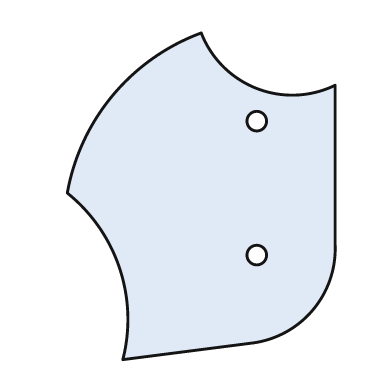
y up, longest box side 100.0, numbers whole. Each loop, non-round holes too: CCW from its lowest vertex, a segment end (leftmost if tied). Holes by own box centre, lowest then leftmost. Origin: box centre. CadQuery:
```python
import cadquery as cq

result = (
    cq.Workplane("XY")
    .moveTo(-24.0, -50.0)
    .lineTo(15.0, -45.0)
    .threePointArc((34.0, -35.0), (41.0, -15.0))
    .lineTo(41.0, 34.0)
    .threePointArc((17.0, 33.0), (0.0, 50.0))
    .threePointArc((-27.0, 31.0), (-41.0, 1.0))
    .threePointArc((-25.0, -22.0), (-24.0, -50.0))
    .close()
    .moveTo(17.0, -18.0)
    .circle(3.0)
    .moveTo(17.0, 23.0)
    .circle(3.0)
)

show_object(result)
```